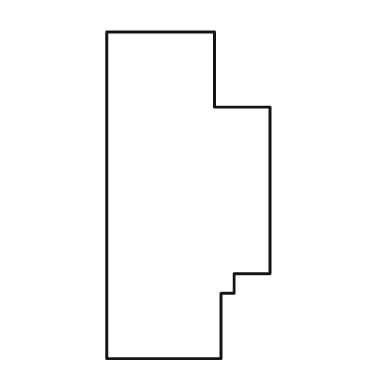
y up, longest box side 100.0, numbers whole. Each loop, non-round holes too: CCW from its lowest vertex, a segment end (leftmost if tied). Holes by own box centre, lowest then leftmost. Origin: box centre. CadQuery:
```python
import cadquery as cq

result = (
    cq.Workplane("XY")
    .moveTo(-25.0, -50.0)
    .lineTo(10.0, -50.0)
    .lineTo(10.0, -30.0)
    .lineTo(14.0, -30.0)
    .lineTo(14.0, -24.0)
    .lineTo(25.0, -24.0)
    .lineTo(25.0, 27.0)
    .lineTo(8.0, 27.0)
    .lineTo(8.0, 50.0)
    .lineTo(-25.0, 50.0)
    .close()
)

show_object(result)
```